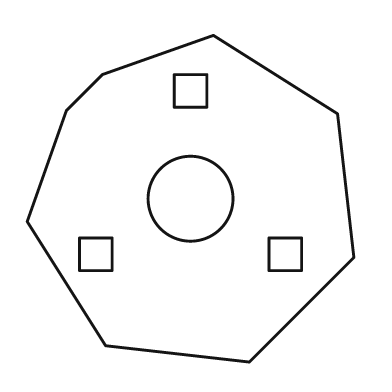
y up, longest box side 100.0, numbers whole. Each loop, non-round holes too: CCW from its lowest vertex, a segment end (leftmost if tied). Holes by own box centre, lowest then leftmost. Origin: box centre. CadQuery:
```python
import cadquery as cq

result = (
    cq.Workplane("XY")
    .moveTo(18.0, -50.0)
    .lineTo(50.0, -18.0)
    .lineTo(45.0, 26.0)
    .lineTo(7.0, 50.0)
    .lineTo(-27.0, 38.0)
    .lineTo(-38.0, 27.0)
    .lineTo(-50.0, -7.0)
    .lineTo(-26.0, -45.0)
    .close()
    .moveTo(-34.0, -22.0)
    .lineTo(-24.0, -22.0)
    .lineTo(-24.0, -12.0)
    .lineTo(-34.0, -12.0)
    .close()
    .moveTo(24.0, -22.0)
    .lineTo(34.0, -22.0)
    .lineTo(34.0, -12.0)
    .lineTo(24.0, -12.0)
    .close()
    .moveTo(0.0, 0.0)
    .circle(13.0)
    .moveTo(-5.0, 28.0)
    .lineTo(5.0, 28.0)
    .lineTo(5.0, 38.0)
    .lineTo(-5.0, 38.0)
    .close()
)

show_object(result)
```